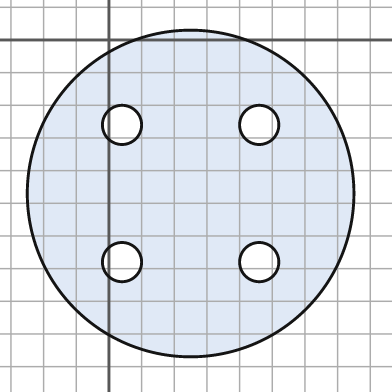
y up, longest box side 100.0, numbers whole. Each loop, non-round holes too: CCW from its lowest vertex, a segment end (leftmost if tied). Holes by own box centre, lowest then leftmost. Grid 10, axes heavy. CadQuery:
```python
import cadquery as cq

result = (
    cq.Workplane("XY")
    .moveTo(25.0, -47.0)
    .circle(50.0)
    .moveTo(4.0, -68.0)
    .circle(6.0)
    .moveTo(46.0, -68.0)
    .circle(6.0)
    .moveTo(4.0, -26.0)
    .circle(6.0)
    .moveTo(46.0, -26.0)
    .circle(6.0)
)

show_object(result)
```